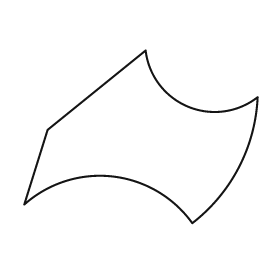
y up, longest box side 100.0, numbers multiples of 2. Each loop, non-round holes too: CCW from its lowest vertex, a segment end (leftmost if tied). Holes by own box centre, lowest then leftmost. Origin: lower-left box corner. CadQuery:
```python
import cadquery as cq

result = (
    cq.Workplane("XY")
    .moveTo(72.0, 0.0)
    .threePointArc((92.0, 24.0), (100.0, 54.0))
    .threePointArc((70.0, 50.0), (52.0, 74.0))
    .lineTo(10.0, 40.0)
    .lineTo(0.0, 8.0)
    .threePointArc((38.0, 20.0), (72.0, 0.0))
    .close()
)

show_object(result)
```